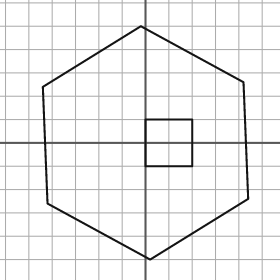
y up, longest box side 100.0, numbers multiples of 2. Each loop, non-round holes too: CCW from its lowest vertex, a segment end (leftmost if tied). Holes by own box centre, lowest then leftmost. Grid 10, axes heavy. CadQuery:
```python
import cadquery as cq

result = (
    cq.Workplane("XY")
    .moveTo(2.0, -50.0)
    .lineTo(44.0, -24.0)
    .lineTo(42.0, 26.0)
    .lineTo(-2.0, 50.0)
    .lineTo(-44.0, 24.0)
    .lineTo(-42.0, -26.0)
    .close()
    .moveTo(0.0, -10.0)
    .lineTo(20.0, -10.0)
    .lineTo(20.0, 10.0)
    .lineTo(0.0, 10.0)
    .close()
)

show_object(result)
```